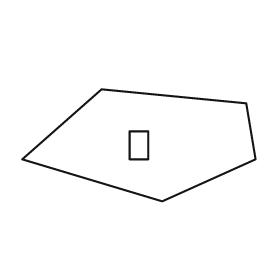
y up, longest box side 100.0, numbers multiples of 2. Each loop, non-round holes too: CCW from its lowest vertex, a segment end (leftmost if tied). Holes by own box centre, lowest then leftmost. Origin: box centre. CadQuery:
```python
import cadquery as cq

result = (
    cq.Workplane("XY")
    .moveTo(10.0, -24.0)
    .lineTo(50.0, -6.0)
    .lineTo(46.0, 18.0)
    .lineTo(-16.0, 24.0)
    .lineTo(-50.0, -6.0)
    .close()
    .moveTo(-4.0, -6.0)
    .lineTo(4.0, -6.0)
    .lineTo(4.0, 6.0)
    .lineTo(-4.0, 6.0)
    .close()
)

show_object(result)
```